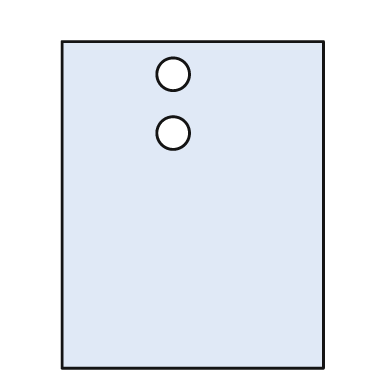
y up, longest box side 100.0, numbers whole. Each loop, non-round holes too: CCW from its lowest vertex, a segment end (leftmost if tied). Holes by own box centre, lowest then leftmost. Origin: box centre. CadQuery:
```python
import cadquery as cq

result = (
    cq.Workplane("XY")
    .moveTo(-40.0, -50.0)
    .lineTo(40.0, -50.0)
    .lineTo(40.0, 50.0)
    .lineTo(-40.0, 50.0)
    .close()
    .moveTo(-6.0, 22.0)
    .circle(5.0)
    .moveTo(-6.0, 40.0)
    .circle(5.0)
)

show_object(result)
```